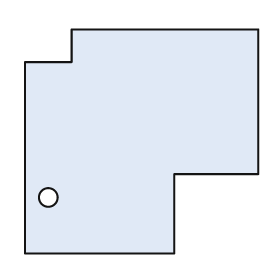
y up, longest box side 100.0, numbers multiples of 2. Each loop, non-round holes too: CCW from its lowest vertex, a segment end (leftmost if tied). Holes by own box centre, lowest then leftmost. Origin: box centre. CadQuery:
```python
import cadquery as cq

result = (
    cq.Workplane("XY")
    .moveTo(-50.0, -48.0)
    .lineTo(14.0, -48.0)
    .lineTo(14.0, -14.0)
    .lineTo(50.0, -14.0)
    .lineTo(50.0, 48.0)
    .lineTo(-30.0, 48.0)
    .lineTo(-30.0, 34.0)
    .lineTo(-50.0, 34.0)
    .close()
    .moveTo(-40.0, -24.0)
    .circle(4.0)
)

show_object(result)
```